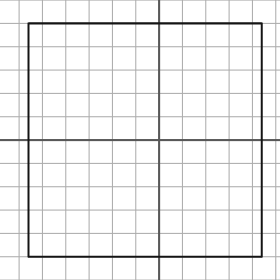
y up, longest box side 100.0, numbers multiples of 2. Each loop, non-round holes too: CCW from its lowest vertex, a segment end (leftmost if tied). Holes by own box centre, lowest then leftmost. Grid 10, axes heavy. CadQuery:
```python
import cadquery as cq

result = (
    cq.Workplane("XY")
    .moveTo(-56.0, -50.0)
    .lineTo(44.0, -50.0)
    .lineTo(44.0, 50.0)
    .lineTo(-56.0, 50.0)
    .close()
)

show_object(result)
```